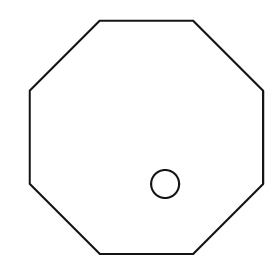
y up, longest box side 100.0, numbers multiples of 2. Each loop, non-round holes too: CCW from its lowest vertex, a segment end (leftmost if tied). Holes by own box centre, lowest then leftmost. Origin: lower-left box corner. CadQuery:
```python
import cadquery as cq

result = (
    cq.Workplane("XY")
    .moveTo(30.0, 0.0)
    .lineTo(70.0, 0.0)
    .lineTo(100.0, 30.0)
    .lineTo(100.0, 70.0)
    .lineTo(70.0, 100.0)
    .lineTo(30.0, 100.0)
    .lineTo(0.0, 70.0)
    .lineTo(0.0, 30.0)
    .close()
    .moveTo(58.0, 30.0)
    .circle(6.0)
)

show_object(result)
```